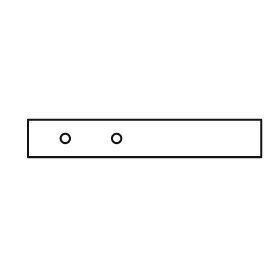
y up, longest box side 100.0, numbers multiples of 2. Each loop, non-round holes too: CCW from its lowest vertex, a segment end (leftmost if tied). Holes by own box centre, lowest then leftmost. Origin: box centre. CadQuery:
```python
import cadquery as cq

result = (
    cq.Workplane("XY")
    .moveTo(-50.0, -8.0)
    .lineTo(50.0, -8.0)
    .lineTo(50.0, 8.0)
    .lineTo(-50.0, 8.0)
    .close()
    .moveTo(-34.0, 0.0)
    .circle(2.0)
    .moveTo(-12.0, 0.0)
    .circle(2.0)
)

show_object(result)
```